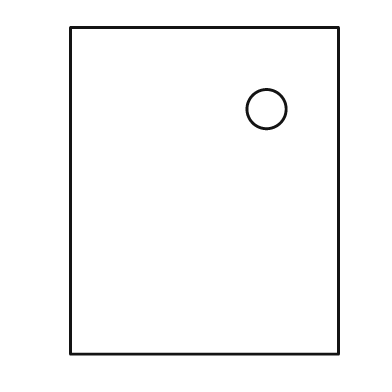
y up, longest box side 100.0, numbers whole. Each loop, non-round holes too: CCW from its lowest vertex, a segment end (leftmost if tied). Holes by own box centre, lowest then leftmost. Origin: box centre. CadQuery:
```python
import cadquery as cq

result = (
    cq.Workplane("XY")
    .moveTo(-41.0, -50.0)
    .lineTo(41.0, -50.0)
    .lineTo(41.0, 50.0)
    .lineTo(-41.0, 50.0)
    .close()
    .moveTo(19.0, 25.0)
    .circle(6.0)
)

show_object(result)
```